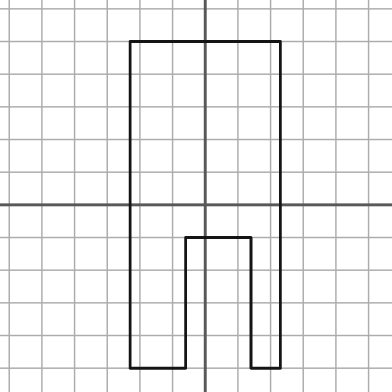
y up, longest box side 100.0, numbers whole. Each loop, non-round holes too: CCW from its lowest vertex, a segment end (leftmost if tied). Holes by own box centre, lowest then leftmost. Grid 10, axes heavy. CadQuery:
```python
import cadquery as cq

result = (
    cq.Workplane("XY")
    .moveTo(-23.0, -50.0)
    .lineTo(-6.0, -50.0)
    .lineTo(-6.0, -10.0)
    .lineTo(14.0, -10.0)
    .lineTo(14.0, -50.0)
    .lineTo(23.0, -50.0)
    .lineTo(23.0, 50.0)
    .lineTo(-23.0, 50.0)
    .close()
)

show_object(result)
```